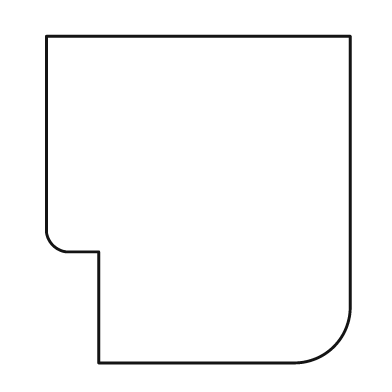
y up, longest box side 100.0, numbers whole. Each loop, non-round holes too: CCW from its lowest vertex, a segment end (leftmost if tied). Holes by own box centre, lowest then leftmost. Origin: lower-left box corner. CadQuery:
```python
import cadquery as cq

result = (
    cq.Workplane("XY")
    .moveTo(16.0, 0.0)
    .lineTo(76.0, 0.0)
    .threePointArc((88.0, 5.0), (93.0, 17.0))
    .lineTo(93.0, 100.0)
    .lineTo(0.0, 100.0)
    .lineTo(0.0, 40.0)
    .threePointArc((2.0, 36.0), (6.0, 34.0))
    .lineTo(16.0, 34.0)
    .close()
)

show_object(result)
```